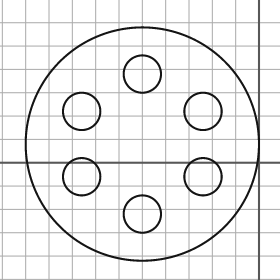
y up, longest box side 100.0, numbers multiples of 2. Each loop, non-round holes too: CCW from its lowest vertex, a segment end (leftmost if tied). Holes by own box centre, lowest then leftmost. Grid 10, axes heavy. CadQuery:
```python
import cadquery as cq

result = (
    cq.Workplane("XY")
    .moveTo(-50.0, 8.0)
    .circle(50.0)
    .moveTo(-50.0, -22.0)
    .circle(8.0)
    .moveTo(-76.0, -6.0)
    .circle(8.0)
    .moveTo(-24.0, -6.0)
    .circle(8.0)
    .moveTo(-76.0, 22.0)
    .circle(8.0)
    .moveTo(-24.0, 22.0)
    .circle(8.0)
    .moveTo(-50.0, 38.0)
    .circle(8.0)
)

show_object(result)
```